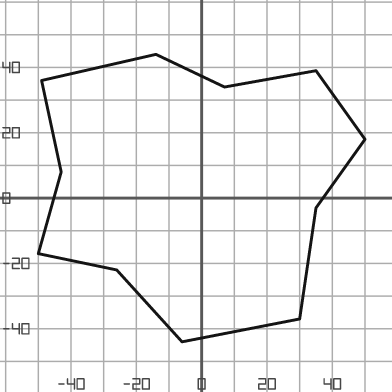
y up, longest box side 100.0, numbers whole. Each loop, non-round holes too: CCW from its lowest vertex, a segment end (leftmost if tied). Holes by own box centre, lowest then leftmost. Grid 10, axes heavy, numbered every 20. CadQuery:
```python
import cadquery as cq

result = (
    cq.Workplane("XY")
    .moveTo(-6.0, -44.0)
    .lineTo(30.0, -37.0)
    .lineTo(35.0, -3.0)
    .lineTo(50.0, 18.0)
    .lineTo(35.0, 39.0)
    .lineTo(7.0, 34.0)
    .lineTo(-14.0, 44.0)
    .lineTo(-49.0, 36.0)
    .lineTo(-43.0, 8.0)
    .lineTo(-50.0, -17.0)
    .lineTo(-26.0, -22.0)
    .close()
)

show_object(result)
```